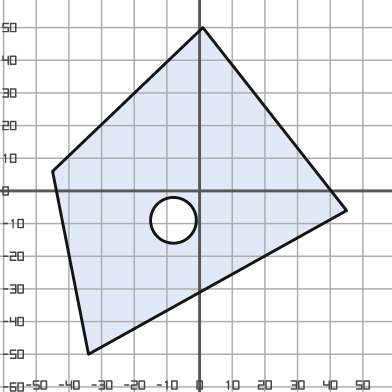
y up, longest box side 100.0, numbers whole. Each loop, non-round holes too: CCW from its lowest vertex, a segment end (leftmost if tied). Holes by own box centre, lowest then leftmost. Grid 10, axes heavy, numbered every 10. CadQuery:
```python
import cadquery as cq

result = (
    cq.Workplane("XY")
    .moveTo(-34.0, -50.0)
    .lineTo(45.0, -6.0)
    .lineTo(1.0, 50.0)
    .lineTo(-45.0, 6.0)
    .close()
    .moveTo(-8.0, -9.0)
    .circle(7.0)
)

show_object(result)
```